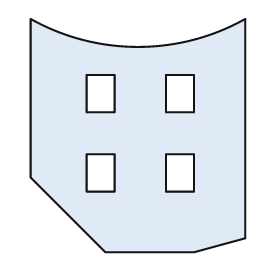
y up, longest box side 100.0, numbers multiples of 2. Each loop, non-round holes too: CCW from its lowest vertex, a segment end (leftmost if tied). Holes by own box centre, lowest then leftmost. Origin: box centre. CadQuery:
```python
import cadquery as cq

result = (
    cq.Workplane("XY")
    .moveTo(-14.0, -50.0)
    .lineTo(24.0, -50.0)
    .lineTo(46.0, -44.0)
    .lineTo(46.0, 50.0)
    .threePointArc((0.0, 38.0), (-46.0, 50.0))
    .lineTo(-46.0, -18.0)
    .close()
    .moveTo(-22.0, -24.0)
    .lineTo(-10.0, -24.0)
    .lineTo(-10.0, -8.0)
    .lineTo(-22.0, -8.0)
    .close()
    .moveTo(12.0, -24.0)
    .lineTo(24.0, -24.0)
    .lineTo(24.0, -8.0)
    .lineTo(12.0, -8.0)
    .close()
    .moveTo(-22.0, 10.0)
    .lineTo(-10.0, 10.0)
    .lineTo(-10.0, 26.0)
    .lineTo(-22.0, 26.0)
    .close()
    .moveTo(12.0, 10.0)
    .lineTo(24.0, 10.0)
    .lineTo(24.0, 26.0)
    .lineTo(12.0, 26.0)
    .close()
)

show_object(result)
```